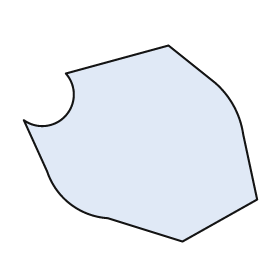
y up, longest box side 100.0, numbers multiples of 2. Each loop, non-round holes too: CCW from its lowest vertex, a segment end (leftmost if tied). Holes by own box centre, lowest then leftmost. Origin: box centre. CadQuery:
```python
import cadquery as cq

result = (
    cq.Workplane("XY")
    .moveTo(18.0, -42.0)
    .lineTo(50.0, -24.0)
    .lineTo(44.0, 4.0)
    .threePointArc((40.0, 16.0), (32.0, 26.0))
    .lineTo(12.0, 42.0)
    .lineTo(-32.0, 30.0)
    .threePointArc((-32.0, 12.0), (-50.0, 10.0))
    .lineTo(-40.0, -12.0)
    .threePointArc((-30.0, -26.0), (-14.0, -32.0))
    .close()
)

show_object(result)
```